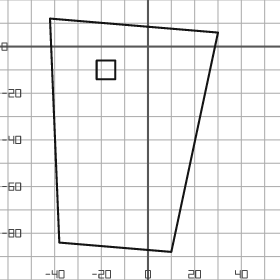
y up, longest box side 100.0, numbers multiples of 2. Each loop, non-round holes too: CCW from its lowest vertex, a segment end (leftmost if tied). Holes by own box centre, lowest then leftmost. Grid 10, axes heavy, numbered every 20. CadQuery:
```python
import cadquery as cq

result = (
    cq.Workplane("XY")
    .moveTo(10.0, -88.0)
    .lineTo(30.0, 6.0)
    .lineTo(-42.0, 12.0)
    .lineTo(-38.0, -84.0)
    .close()
    .moveTo(-22.0, -14.0)
    .lineTo(-14.0, -14.0)
    .lineTo(-14.0, -6.0)
    .lineTo(-22.0, -6.0)
    .close()
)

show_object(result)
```